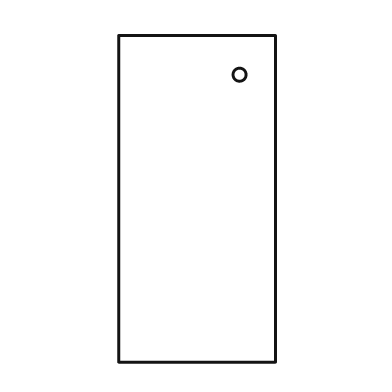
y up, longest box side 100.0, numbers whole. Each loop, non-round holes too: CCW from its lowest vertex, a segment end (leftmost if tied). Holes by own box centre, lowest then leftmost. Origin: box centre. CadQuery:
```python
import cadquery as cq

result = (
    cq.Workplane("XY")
    .moveTo(-24.0, -50.0)
    .lineTo(24.0, -50.0)
    .lineTo(24.0, 50.0)
    .lineTo(-24.0, 50.0)
    .close()
    .moveTo(13.0, 38.0)
    .circle(2.0)
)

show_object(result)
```